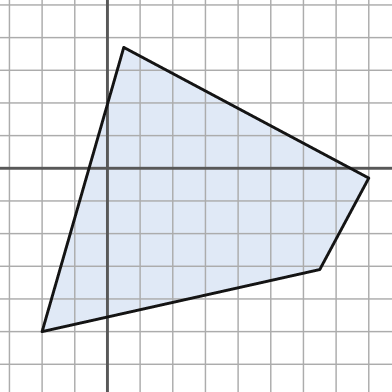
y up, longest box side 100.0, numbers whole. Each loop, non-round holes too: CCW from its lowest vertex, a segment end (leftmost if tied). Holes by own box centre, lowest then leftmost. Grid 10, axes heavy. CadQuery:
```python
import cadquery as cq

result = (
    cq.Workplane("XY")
    .moveTo(-20.0, -50.0)
    .lineTo(65.0, -31.0)
    .lineTo(80.0, -3.0)
    .lineTo(5.0, 37.0)
    .close()
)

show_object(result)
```